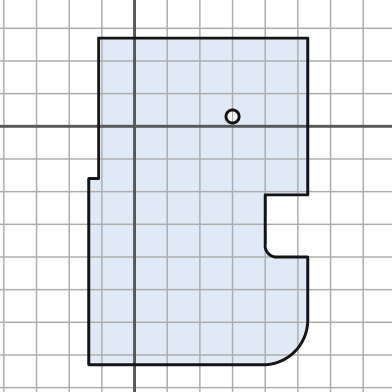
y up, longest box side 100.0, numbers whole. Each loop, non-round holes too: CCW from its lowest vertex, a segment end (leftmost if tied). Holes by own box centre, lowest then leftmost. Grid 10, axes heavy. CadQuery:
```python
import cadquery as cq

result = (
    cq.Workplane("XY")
    .moveTo(-14.0, -73.0)
    .lineTo(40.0, -73.0)
    .threePointArc((49.0, -69.0), (53.0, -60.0))
    .lineTo(53.0, -40.0)
    .lineTo(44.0, -40.0)
    .threePointArc((41.0, -39.0), (40.0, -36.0))
    .lineTo(40.0, -21.0)
    .lineTo(53.0, -21.0)
    .lineTo(53.0, 27.0)
    .lineTo(-11.0, 27.0)
    .lineTo(-11.0, -16.0)
    .lineTo(-14.0, -16.0)
    .close()
    .moveTo(30.0, 3.0)
    .circle(2.0)
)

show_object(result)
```